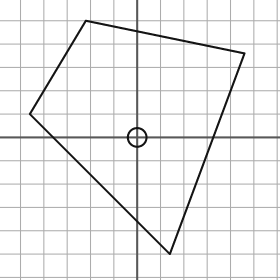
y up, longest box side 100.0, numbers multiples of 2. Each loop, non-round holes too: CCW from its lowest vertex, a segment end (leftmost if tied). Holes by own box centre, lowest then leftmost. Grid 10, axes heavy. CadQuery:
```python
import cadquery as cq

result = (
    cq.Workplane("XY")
    .moveTo(14.0, -50.0)
    .lineTo(46.0, 36.0)
    .lineTo(-22.0, 50.0)
    .lineTo(-46.0, 10.0)
    .close()
    .moveTo(0.0, 0.0)
    .circle(4.0)
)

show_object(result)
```